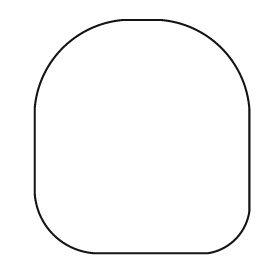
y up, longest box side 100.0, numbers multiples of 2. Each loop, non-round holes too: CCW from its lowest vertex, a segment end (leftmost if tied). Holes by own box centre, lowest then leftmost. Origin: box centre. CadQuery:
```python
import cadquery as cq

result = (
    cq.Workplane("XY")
    .moveTo(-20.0, -50.0)
    .lineTo(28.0, -50.0)
    .threePointArc((40.0, -44.0), (46.0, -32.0))
    .lineTo(46.0, 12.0)
    .threePointArc((34.0, 38.0), (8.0, 50.0))
    .lineTo(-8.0, 50.0)
    .threePointArc((-34.0, 38.0), (-46.0, 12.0))
    .lineTo(-46.0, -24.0)
    .threePointArc((-38.0, -42.0), (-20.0, -50.0))
    .close()
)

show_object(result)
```